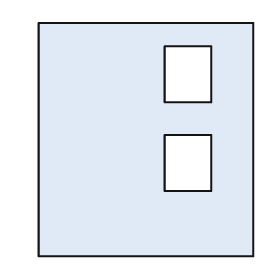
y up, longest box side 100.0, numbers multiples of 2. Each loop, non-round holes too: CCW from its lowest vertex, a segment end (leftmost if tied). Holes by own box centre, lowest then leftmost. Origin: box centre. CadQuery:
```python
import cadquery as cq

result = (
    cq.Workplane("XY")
    .moveTo(-46.0, -50.0)
    .lineTo(46.0, -50.0)
    .lineTo(46.0, 50.0)
    .lineTo(-46.0, 50.0)
    .close()
    .moveTo(8.0, -22.0)
    .lineTo(28.0, -22.0)
    .lineTo(28.0, 2.0)
    .lineTo(8.0, 2.0)
    .close()
    .moveTo(8.0, 16.0)
    .lineTo(28.0, 16.0)
    .lineTo(28.0, 40.0)
    .lineTo(8.0, 40.0)
    .close()
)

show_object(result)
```